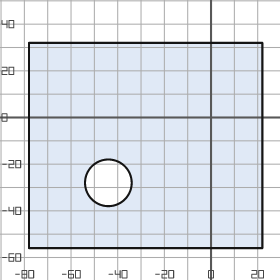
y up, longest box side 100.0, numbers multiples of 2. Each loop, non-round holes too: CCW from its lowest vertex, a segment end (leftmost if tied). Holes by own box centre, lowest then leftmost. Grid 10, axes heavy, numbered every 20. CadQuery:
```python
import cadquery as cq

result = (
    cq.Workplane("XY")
    .moveTo(-78.0, -56.0)
    .lineTo(22.0, -56.0)
    .lineTo(22.0, 32.0)
    .lineTo(-78.0, 32.0)
    .close()
    .moveTo(-44.0, -28.0)
    .circle(10.0)
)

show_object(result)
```